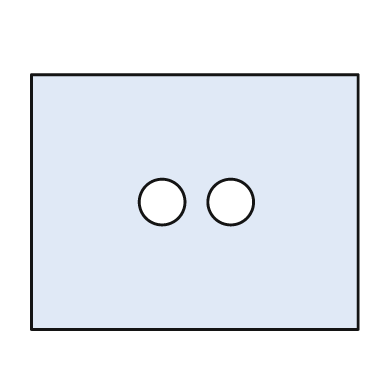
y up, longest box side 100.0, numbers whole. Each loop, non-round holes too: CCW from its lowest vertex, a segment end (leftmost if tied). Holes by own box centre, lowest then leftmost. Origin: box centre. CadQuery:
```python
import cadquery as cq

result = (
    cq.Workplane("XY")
    .moveTo(-50.0, -39.0)
    .lineTo(50.0, -39.0)
    .lineTo(50.0, 39.0)
    .lineTo(-50.0, 39.0)
    .close()
    .moveTo(-10.0, 0.0)
    .circle(7.0)
    .moveTo(11.0, 0.0)
    .circle(7.0)
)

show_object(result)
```